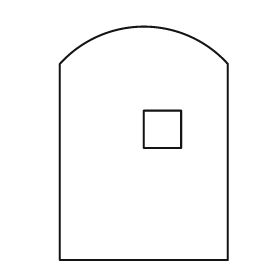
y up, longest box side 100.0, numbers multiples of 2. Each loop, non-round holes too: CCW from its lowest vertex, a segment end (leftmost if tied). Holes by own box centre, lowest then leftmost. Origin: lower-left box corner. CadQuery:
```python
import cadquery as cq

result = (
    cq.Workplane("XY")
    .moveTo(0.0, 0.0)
    .lineTo(72.0, 0.0)
    .lineTo(72.0, 84.0)
    .threePointArc((36.0, 100.0), (0.0, 84.0))
    .close()
    .moveTo(36.0, 48.0)
    .lineTo(52.0, 48.0)
    .lineTo(52.0, 64.0)
    .lineTo(36.0, 64.0)
    .close()
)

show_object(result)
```